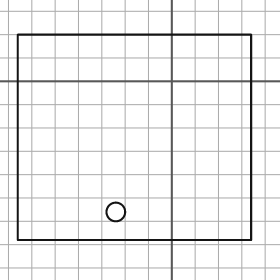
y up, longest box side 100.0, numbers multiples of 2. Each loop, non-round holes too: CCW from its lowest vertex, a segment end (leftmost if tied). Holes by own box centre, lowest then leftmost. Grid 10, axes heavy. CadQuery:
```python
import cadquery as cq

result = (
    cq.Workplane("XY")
    .moveTo(-66.0, -68.0)
    .lineTo(34.0, -68.0)
    .lineTo(34.0, 20.0)
    .lineTo(-66.0, 20.0)
    .close()
    .moveTo(-24.0, -56.0)
    .circle(4.0)
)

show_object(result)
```